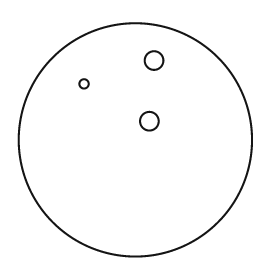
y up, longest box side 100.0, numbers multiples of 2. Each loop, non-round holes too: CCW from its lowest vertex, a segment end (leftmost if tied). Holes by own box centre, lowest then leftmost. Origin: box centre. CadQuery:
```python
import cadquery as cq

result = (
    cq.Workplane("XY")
    .moveTo(0.0, 0.0)
    .circle(50.0)
    .moveTo(6.0, 8.0)
    .circle(4.0)
    .moveTo(-22.0, 24.0)
    .circle(2.0)
    .moveTo(8.0, 34.0)
    .circle(4.0)
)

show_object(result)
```